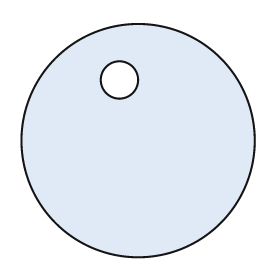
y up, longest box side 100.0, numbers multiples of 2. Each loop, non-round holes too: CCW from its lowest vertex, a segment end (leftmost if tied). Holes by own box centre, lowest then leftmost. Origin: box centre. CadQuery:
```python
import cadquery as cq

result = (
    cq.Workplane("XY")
    .moveTo(0.0, 0.0)
    .circle(50.0)
    .moveTo(-8.0, 26.0)
    .circle(8.0)
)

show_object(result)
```